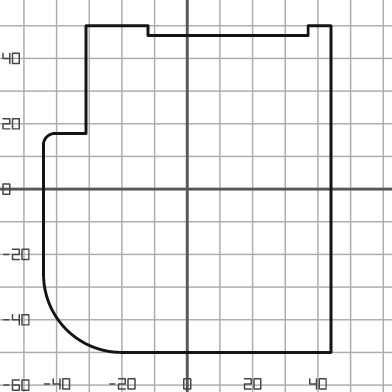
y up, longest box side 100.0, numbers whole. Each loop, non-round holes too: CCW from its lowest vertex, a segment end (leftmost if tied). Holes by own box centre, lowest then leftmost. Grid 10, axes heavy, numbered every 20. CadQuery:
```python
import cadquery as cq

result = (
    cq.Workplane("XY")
    .moveTo(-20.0, -50.0)
    .lineTo(44.0, -50.0)
    .lineTo(44.0, 50.0)
    .lineTo(37.0, 50.0)
    .lineTo(37.0, 47.0)
    .lineTo(-12.0, 47.0)
    .lineTo(-12.0, 50.0)
    .lineTo(-31.0, 50.0)
    .lineTo(-31.0, 17.0)
    .lineTo(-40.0, 17.0)
    .threePointArc((-43.0, 16.0), (-44.0, 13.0))
    .lineTo(-44.0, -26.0)
    .threePointArc((-37.0, -43.0), (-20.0, -50.0))
    .close()
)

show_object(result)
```